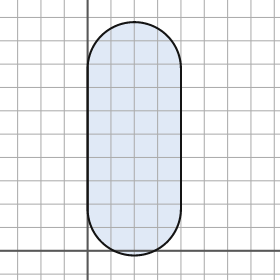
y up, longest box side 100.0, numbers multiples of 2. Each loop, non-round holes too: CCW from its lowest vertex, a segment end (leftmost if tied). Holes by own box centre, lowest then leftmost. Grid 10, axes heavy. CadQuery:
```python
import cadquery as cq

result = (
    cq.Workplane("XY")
    .moveTo(0.0, 18.0)
    .threePointArc((20.0, -2.0), (40.0, 18.0))
    .lineTo(40.0, 78.0)
    .threePointArc((20.0, 98.0), (0.0, 78.0))
    .close()
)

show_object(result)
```